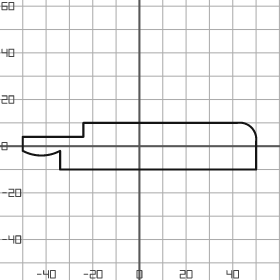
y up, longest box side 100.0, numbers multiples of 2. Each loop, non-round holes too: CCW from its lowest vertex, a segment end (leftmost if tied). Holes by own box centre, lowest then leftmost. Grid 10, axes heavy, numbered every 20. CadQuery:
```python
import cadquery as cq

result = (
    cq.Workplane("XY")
    .moveTo(-34.0, -10.0)
    .lineTo(50.0, -10.0)
    .lineTo(50.0, 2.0)
    .threePointArc((48.0, 8.0), (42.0, 10.0))
    .lineTo(-24.0, 10.0)
    .lineTo(-24.0, 4.0)
    .lineTo(-50.0, 4.0)
    .lineTo(-50.0, -2.0)
    .threePointArc((-42.0, -4.0), (-34.0, -2.0))
    .close()
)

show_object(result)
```